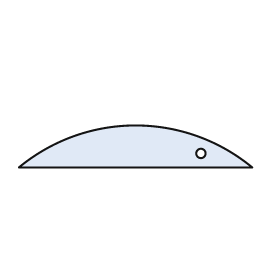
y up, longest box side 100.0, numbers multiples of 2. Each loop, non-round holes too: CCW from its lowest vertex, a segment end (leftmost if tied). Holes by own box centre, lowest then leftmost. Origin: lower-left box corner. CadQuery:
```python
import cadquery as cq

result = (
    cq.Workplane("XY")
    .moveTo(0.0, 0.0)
    .lineTo(100.0, 0.0)
    .threePointArc((50.0, 18.0), (0.0, 0.0))
    .close()
    .moveTo(78.0, 6.0)
    .circle(2.0)
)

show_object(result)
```